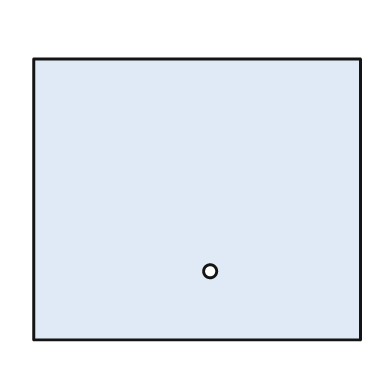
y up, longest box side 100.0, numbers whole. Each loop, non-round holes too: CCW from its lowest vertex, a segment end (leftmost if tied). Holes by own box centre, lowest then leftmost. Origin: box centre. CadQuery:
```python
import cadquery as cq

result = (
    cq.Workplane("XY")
    .moveTo(-50.0, -43.0)
    .lineTo(50.0, -43.0)
    .lineTo(50.0, 43.0)
    .lineTo(-50.0, 43.0)
    .close()
    .moveTo(4.0, -22.0)
    .circle(2.0)
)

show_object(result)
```